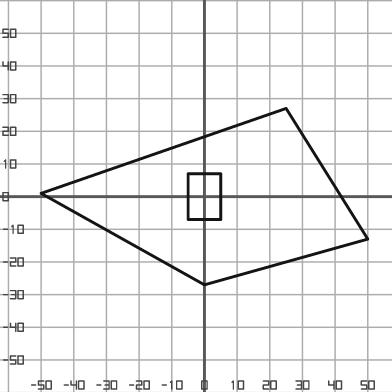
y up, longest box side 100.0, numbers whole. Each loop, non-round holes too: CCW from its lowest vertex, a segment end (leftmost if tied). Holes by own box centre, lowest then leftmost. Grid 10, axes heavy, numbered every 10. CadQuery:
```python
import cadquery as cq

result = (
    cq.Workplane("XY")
    .moveTo(0.0, -27.0)
    .lineTo(50.0, -13.0)
    .lineTo(25.0, 27.0)
    .lineTo(-50.0, 1.0)
    .close()
    .moveTo(-5.0, -7.0)
    .lineTo(5.0, -7.0)
    .lineTo(5.0, 7.0)
    .lineTo(-5.0, 7.0)
    .close()
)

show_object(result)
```